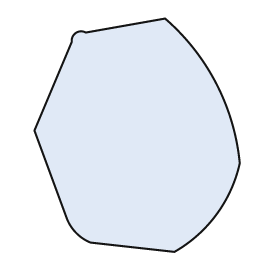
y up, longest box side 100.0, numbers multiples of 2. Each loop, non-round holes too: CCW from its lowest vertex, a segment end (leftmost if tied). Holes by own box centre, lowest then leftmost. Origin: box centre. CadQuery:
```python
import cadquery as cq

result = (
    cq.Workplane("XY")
    .moveTo(16.0, -50.0)
    .threePointArc((34.0, -34.0), (44.0, -12.0))
    .threePointArc((34.0, 22.0), (12.0, 50.0))
    .lineTo(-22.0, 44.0)
    .threePointArc((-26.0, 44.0), (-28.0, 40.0))
    .lineTo(-44.0, 2.0)
    .lineTo(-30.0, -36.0)
    .threePointArc((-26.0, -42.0), (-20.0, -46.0))
    .close()
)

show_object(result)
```